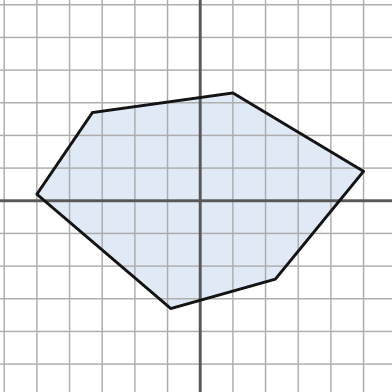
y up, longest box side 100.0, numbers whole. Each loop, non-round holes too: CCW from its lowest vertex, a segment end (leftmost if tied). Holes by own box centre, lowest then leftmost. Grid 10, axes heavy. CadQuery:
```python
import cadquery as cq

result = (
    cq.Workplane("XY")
    .moveTo(-9.0, -33.0)
    .lineTo(23.0, -24.0)
    .lineTo(50.0, 9.0)
    .lineTo(10.0, 33.0)
    .lineTo(-33.0, 27.0)
    .lineTo(-50.0, 2.0)
    .close()
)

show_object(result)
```